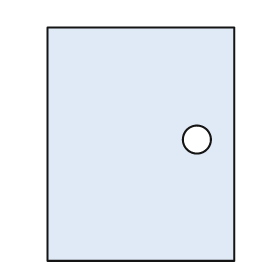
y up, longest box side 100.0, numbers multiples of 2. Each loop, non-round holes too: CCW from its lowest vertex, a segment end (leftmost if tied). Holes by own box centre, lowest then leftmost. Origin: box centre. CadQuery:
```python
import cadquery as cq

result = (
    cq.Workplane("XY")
    .moveTo(-40.0, -50.0)
    .lineTo(40.0, -50.0)
    .lineTo(40.0, 50.0)
    .lineTo(-40.0, 50.0)
    .close()
    .moveTo(24.0, 2.0)
    .circle(6.0)
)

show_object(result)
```